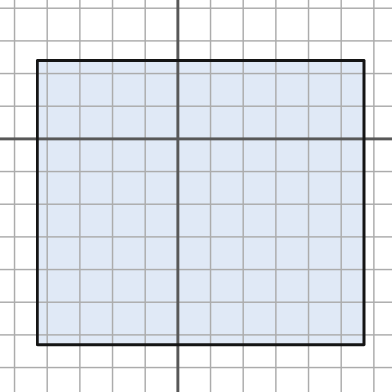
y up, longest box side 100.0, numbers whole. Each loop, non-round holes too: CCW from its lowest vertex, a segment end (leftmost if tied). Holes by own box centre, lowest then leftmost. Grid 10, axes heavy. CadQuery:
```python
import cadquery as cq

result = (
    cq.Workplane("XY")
    .moveTo(-43.0, -63.0)
    .lineTo(57.0, -63.0)
    .lineTo(57.0, 24.0)
    .lineTo(-43.0, 24.0)
    .close()
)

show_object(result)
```